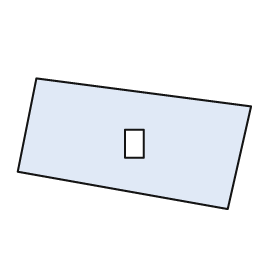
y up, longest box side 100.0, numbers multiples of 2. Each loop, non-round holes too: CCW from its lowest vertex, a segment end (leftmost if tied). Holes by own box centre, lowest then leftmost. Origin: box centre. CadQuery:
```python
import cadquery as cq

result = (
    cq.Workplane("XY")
    .moveTo(40.0, -28.0)
    .lineTo(50.0, 16.0)
    .lineTo(-42.0, 28.0)
    .lineTo(-50.0, -12.0)
    .close()
    .moveTo(-4.0, -6.0)
    .lineTo(4.0, -6.0)
    .lineTo(4.0, 6.0)
    .lineTo(-4.0, 6.0)
    .close()
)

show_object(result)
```